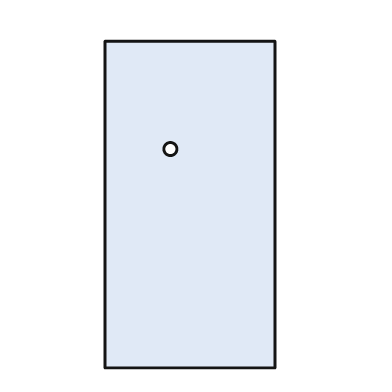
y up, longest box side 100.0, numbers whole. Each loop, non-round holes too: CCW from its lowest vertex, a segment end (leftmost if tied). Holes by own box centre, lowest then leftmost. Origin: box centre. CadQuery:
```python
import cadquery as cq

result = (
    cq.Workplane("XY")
    .moveTo(-26.0, -50.0)
    .lineTo(26.0, -50.0)
    .lineTo(26.0, 50.0)
    .lineTo(-26.0, 50.0)
    .close()
    .moveTo(-6.0, 17.0)
    .circle(2.0)
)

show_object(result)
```